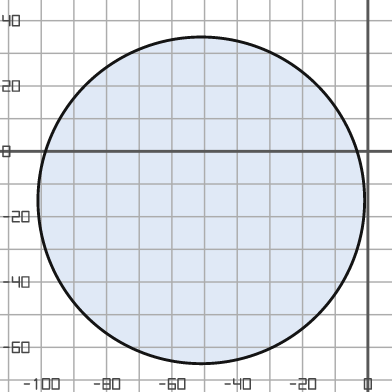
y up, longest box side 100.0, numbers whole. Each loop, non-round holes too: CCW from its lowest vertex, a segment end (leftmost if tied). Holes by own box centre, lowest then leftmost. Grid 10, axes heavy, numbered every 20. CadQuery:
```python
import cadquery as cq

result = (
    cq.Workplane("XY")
    .moveTo(-51.0, -15.0)
    .circle(50.0)
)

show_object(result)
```